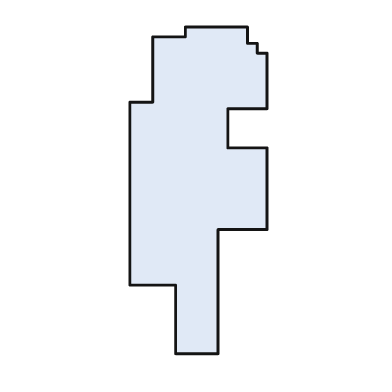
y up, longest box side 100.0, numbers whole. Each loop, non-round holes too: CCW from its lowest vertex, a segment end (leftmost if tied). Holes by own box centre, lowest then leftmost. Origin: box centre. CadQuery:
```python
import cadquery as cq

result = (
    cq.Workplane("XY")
    .moveTo(-7.0, -50.0)
    .lineTo(6.0, -50.0)
    .lineTo(6.0, -12.0)
    .lineTo(21.0, -12.0)
    .lineTo(21.0, 13.0)
    .lineTo(9.0, 13.0)
    .lineTo(9.0, 25.0)
    .lineTo(21.0, 25.0)
    .lineTo(21.0, 42.0)
    .lineTo(18.0, 42.0)
    .lineTo(18.0, 45.0)
    .lineTo(15.0, 45.0)
    .lineTo(15.0, 50.0)
    .lineTo(-4.0, 50.0)
    .lineTo(-4.0, 47.0)
    .lineTo(-14.0, 47.0)
    .lineTo(-14.0, 27.0)
    .lineTo(-21.0, 27.0)
    .lineTo(-21.0, -29.0)
    .lineTo(-7.0, -29.0)
    .close()
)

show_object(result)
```